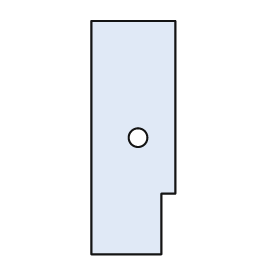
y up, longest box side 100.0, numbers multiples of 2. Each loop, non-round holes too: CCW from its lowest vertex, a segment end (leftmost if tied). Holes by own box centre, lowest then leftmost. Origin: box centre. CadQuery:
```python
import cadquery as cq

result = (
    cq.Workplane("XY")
    .moveTo(-18.0, -50.0)
    .lineTo(12.0, -50.0)
    .lineTo(12.0, -24.0)
    .lineTo(18.0, -24.0)
    .lineTo(18.0, 50.0)
    .lineTo(-18.0, 50.0)
    .close()
    .moveTo(2.0, 0.0)
    .circle(4.0)
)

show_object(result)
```